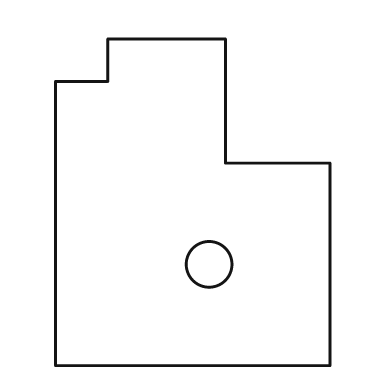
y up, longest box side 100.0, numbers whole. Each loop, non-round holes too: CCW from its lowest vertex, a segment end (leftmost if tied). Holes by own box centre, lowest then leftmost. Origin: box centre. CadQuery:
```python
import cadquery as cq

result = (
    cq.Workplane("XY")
    .moveTo(-42.0, -50.0)
    .lineTo(42.0, -50.0)
    .lineTo(42.0, 12.0)
    .lineTo(10.0, 12.0)
    .lineTo(10.0, 50.0)
    .lineTo(-26.0, 50.0)
    .lineTo(-26.0, 37.0)
    .lineTo(-42.0, 37.0)
    .close()
    .moveTo(5.0, -19.0)
    .circle(7.0)
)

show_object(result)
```